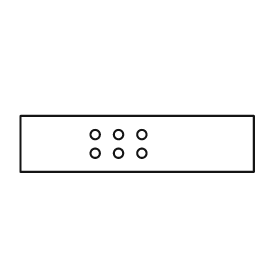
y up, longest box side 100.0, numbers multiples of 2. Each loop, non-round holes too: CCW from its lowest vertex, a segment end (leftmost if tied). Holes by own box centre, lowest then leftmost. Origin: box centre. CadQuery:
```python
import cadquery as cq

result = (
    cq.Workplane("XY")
    .moveTo(-50.0, -12.0)
    .lineTo(50.0, -12.0)
    .lineTo(50.0, 12.0)
    .lineTo(-50.0, 12.0)
    .close()
    .moveTo(-18.0, -4.0)
    .circle(2.0)
    .moveTo(-8.0, -4.0)
    .circle(2.0)
    .moveTo(2.0, -4.0)
    .circle(2.0)
    .moveTo(-18.0, 4.0)
    .circle(2.0)
    .moveTo(-8.0, 4.0)
    .circle(2.0)
    .moveTo(2.0, 4.0)
    .circle(2.0)
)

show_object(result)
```